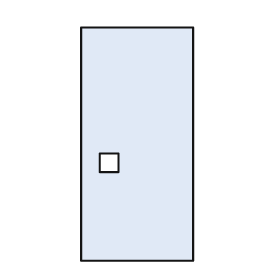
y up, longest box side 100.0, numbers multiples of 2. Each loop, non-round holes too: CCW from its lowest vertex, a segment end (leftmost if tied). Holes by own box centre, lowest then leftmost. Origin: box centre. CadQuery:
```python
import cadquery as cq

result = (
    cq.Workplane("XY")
    .moveTo(-24.0, -50.0)
    .lineTo(24.0, -50.0)
    .lineTo(24.0, 50.0)
    .lineTo(-24.0, 50.0)
    .close()
    .moveTo(-16.0, -12.0)
    .lineTo(-8.0, -12.0)
    .lineTo(-8.0, -4.0)
    .lineTo(-16.0, -4.0)
    .close()
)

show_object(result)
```